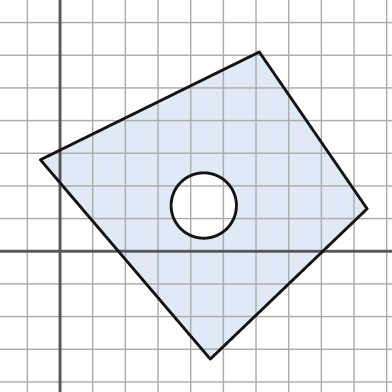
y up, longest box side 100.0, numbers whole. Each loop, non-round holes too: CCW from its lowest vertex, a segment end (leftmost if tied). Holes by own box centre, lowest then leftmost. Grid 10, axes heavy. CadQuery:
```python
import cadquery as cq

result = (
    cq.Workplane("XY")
    .moveTo(46.0, -33.0)
    .lineTo(94.0, 13.0)
    .lineTo(61.0, 61.0)
    .lineTo(-6.0, 28.0)
    .close()
    .moveTo(44.0, 14.0)
    .circle(10.0)
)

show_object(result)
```